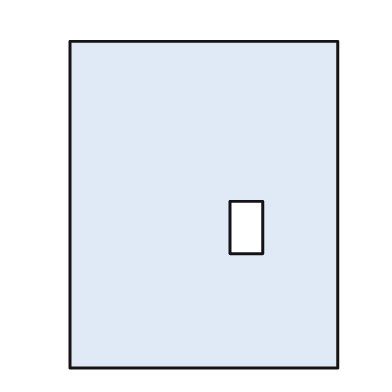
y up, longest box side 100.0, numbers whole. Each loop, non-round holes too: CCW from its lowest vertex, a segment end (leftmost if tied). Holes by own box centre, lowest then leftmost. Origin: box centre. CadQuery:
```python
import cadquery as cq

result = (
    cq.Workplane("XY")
    .moveTo(-41.0, -50.0)
    .lineTo(41.0, -50.0)
    .lineTo(41.0, 50.0)
    .lineTo(-41.0, 50.0)
    .close()
    .moveTo(8.0, -15.0)
    .lineTo(18.0, -15.0)
    .lineTo(18.0, 1.0)
    .lineTo(8.0, 1.0)
    .close()
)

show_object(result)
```